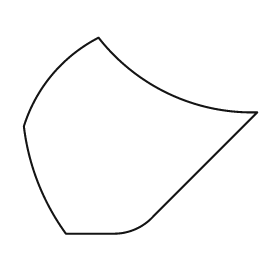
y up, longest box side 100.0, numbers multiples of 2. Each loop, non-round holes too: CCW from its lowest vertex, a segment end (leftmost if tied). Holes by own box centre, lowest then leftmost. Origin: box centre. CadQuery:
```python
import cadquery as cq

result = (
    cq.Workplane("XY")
    .moveTo(-32.0, -42.0)
    .lineTo(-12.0, -42.0)
    .threePointArc((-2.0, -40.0), (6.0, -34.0))
    .lineTo(50.0, 10.0)
    .threePointArc((12.0, 18.0), (-18.0, 42.0))
    .threePointArc((-38.0, 26.0), (-50.0, 4.0))
    .threePointArc((-44.0, -20.0), (-32.0, -42.0))
    .close()
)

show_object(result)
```